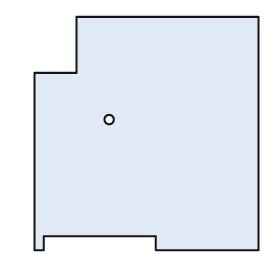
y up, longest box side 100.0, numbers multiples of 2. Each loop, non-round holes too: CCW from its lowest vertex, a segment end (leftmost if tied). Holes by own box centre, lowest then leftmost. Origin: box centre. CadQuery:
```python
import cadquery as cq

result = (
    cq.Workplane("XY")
    .moveTo(-48.0, -50.0)
    .lineTo(-44.0, -50.0)
    .lineTo(-44.0, -44.0)
    .lineTo(4.0, -44.0)
    .lineTo(4.0, -50.0)
    .lineTo(48.0, -50.0)
    .lineTo(48.0, 50.0)
    .lineTo(-30.0, 50.0)
    .lineTo(-30.0, 26.0)
    .lineTo(-48.0, 26.0)
    .close()
    .moveTo(-16.0, 6.0)
    .circle(2.0)
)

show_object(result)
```